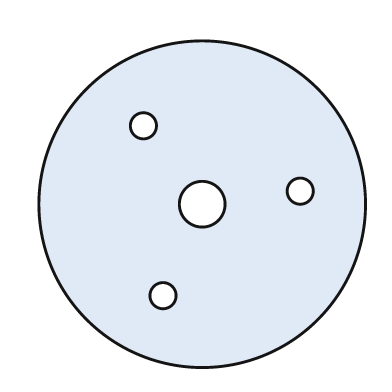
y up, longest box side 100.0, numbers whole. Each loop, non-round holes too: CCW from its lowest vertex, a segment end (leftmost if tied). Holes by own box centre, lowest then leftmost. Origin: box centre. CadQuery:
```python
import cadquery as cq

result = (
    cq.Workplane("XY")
    .moveTo(0.0, 0.0)
    .circle(50.0)
    .moveTo(-12.0, -28.0)
    .circle(4.0)
    .moveTo(0.0, 0.0)
    .circle(7.0)
    .moveTo(30.0, 4.0)
    .circle(4.0)
    .moveTo(-18.0, 24.0)
    .circle(4.0)
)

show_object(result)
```